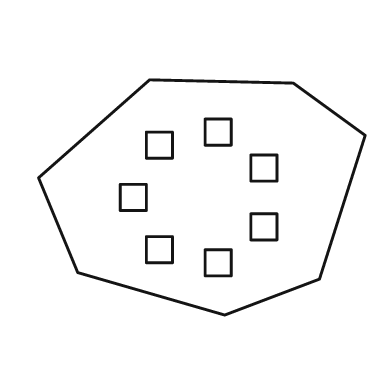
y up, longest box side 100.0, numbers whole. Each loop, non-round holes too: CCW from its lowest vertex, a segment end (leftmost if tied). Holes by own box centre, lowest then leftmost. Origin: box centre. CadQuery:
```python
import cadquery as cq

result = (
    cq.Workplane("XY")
    .moveTo(7.0, -36.0)
    .lineTo(36.0, -25.0)
    .lineTo(50.0, 19.0)
    .lineTo(28.0, 35.0)
    .lineTo(-16.0, 36.0)
    .lineTo(-50.0, 6.0)
    .lineTo(-38.0, -23.0)
    .close()
    .moveTo(1.0, -24.0)
    .lineTo(9.0, -24.0)
    .lineTo(9.0, -16.0)
    .lineTo(1.0, -16.0)
    .close()
    .moveTo(-17.0, -20.0)
    .lineTo(-9.0, -20.0)
    .lineTo(-9.0, -12.0)
    .lineTo(-17.0, -12.0)
    .close()
    .moveTo(15.0, -13.0)
    .lineTo(23.0, -13.0)
    .lineTo(23.0, -5.0)
    .lineTo(15.0, -5.0)
    .close()
    .moveTo(-25.0, -4.0)
    .lineTo(-17.0, -4.0)
    .lineTo(-17.0, 4.0)
    .lineTo(-25.0, 4.0)
    .close()
    .moveTo(15.0, 5.0)
    .lineTo(23.0, 5.0)
    .lineTo(23.0, 13.0)
    .lineTo(15.0, 13.0)
    .close()
    .moveTo(-17.0, 12.0)
    .lineTo(-9.0, 12.0)
    .lineTo(-9.0, 20.0)
    .lineTo(-17.0, 20.0)
    .close()
    .moveTo(1.0, 16.0)
    .lineTo(9.0, 16.0)
    .lineTo(9.0, 24.0)
    .lineTo(1.0, 24.0)
    .close()
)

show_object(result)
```